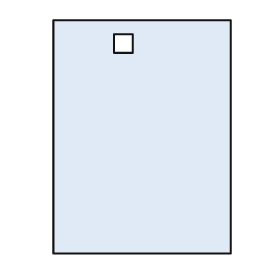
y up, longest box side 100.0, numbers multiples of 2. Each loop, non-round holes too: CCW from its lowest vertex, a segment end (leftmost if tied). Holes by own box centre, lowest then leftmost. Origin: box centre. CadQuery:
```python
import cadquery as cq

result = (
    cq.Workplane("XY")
    .moveTo(-38.0, -50.0)
    .lineTo(38.0, -50.0)
    .lineTo(38.0, 50.0)
    .lineTo(-38.0, 50.0)
    .close()
    .moveTo(-12.0, 36.0)
    .lineTo(-4.0, 36.0)
    .lineTo(-4.0, 44.0)
    .lineTo(-12.0, 44.0)
    .close()
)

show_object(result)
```